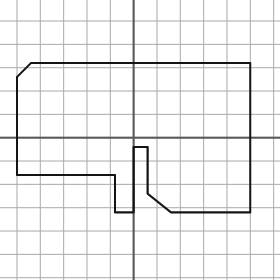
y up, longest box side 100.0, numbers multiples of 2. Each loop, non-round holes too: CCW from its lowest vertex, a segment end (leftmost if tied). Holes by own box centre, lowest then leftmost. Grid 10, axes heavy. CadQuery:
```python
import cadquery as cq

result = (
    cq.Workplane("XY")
    .moveTo(-8.0, -32.0)
    .lineTo(0.0, -32.0)
    .lineTo(0.0, -4.0)
    .lineTo(6.0, -4.0)
    .lineTo(6.0, -24.0)
    .lineTo(16.0, -32.0)
    .lineTo(50.0, -32.0)
    .lineTo(50.0, 32.0)
    .lineTo(-44.0, 32.0)
    .lineTo(-50.0, 26.0)
    .lineTo(-50.0, -16.0)
    .lineTo(-8.0, -16.0)
    .close()
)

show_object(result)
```